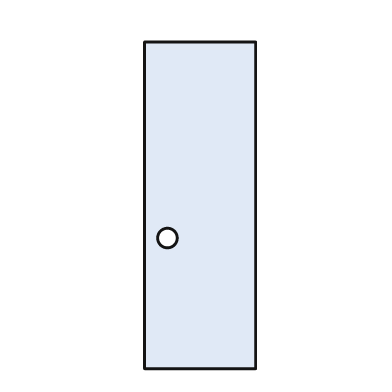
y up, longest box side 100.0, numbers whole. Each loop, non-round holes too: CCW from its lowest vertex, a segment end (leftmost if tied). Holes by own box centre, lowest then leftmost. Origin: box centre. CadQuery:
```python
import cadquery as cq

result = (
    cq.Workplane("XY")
    .moveTo(-17.0, -50.0)
    .lineTo(17.0, -50.0)
    .lineTo(17.0, 50.0)
    .lineTo(-17.0, 50.0)
    .close()
    .moveTo(-10.0, -10.0)
    .circle(3.0)
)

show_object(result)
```